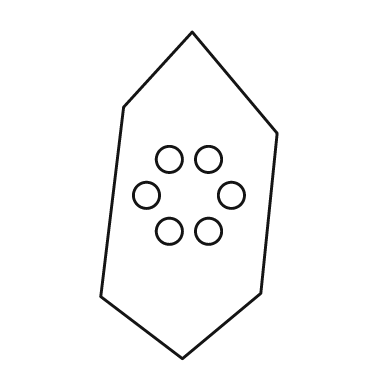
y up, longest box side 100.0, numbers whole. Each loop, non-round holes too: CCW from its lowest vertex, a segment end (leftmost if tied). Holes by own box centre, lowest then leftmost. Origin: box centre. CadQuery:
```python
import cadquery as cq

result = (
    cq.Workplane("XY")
    .moveTo(-2.0, -50.0)
    .lineTo(22.0, -30.0)
    .lineTo(27.0, 19.0)
    .lineTo(1.0, 50.0)
    .lineTo(-20.0, 27.0)
    .lineTo(-27.0, -31.0)
    .close()
    .moveTo(-6.0, -11.0)
    .circle(4.0)
    .moveTo(6.0, -11.0)
    .circle(4.0)
    .moveTo(-13.0, 0.0)
    .circle(4.0)
    .moveTo(13.0, 0.0)
    .circle(4.0)
    .moveTo(-6.0, 11.0)
    .circle(4.0)
    .moveTo(6.0, 11.0)
    .circle(4.0)
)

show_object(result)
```